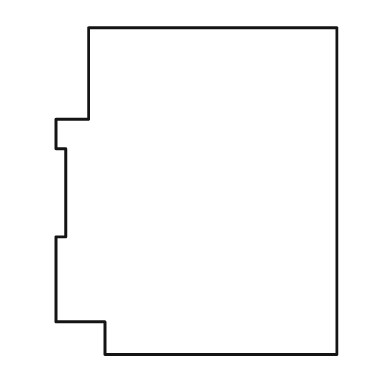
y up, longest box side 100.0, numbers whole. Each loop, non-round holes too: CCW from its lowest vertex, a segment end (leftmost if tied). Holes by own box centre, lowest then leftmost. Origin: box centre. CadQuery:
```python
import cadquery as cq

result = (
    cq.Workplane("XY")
    .moveTo(-28.0, -50.0)
    .lineTo(43.0, -50.0)
    .lineTo(43.0, 50.0)
    .lineTo(-33.0, 50.0)
    .lineTo(-33.0, 22.0)
    .lineTo(-43.0, 22.0)
    .lineTo(-43.0, 13.0)
    .lineTo(-40.0, 13.0)
    .lineTo(-40.0, -14.0)
    .lineTo(-43.0, -14.0)
    .lineTo(-43.0, -40.0)
    .lineTo(-28.0, -40.0)
    .close()
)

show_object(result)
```